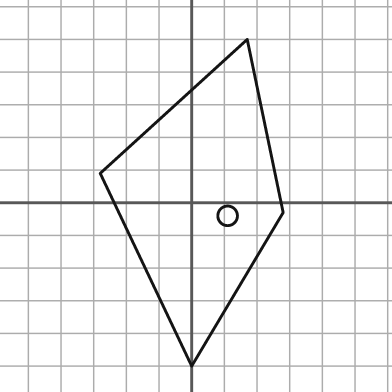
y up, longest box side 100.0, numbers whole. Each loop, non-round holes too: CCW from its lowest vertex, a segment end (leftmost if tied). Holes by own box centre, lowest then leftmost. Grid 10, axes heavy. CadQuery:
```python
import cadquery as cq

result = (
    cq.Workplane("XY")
    .moveTo(0.0, -50.0)
    .lineTo(28.0, -3.0)
    .lineTo(17.0, 50.0)
    .lineTo(-28.0, 9.0)
    .close()
    .moveTo(11.0, -4.0)
    .circle(3.0)
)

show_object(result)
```